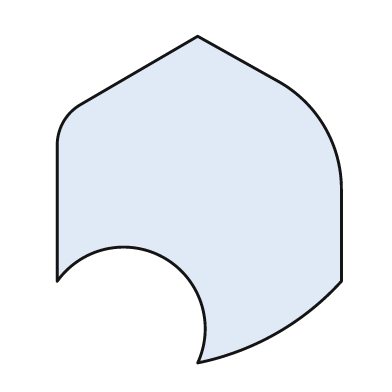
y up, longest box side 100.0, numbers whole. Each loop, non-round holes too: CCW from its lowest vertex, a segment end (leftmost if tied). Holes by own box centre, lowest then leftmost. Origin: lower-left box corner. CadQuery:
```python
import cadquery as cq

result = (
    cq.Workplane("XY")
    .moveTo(43.0, 0.0)
    .threePointArc((67.0, 9.0), (87.0, 25.0))
    .lineTo(87.0, 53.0)
    .threePointArc((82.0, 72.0), (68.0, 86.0))
    .lineTo(43.0, 100.0)
    .lineTo(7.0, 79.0)
    .threePointArc((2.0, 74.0), (0.0, 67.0))
    .lineTo(0.0, 25.0)
    .threePointArc((33.0, 32.0), (43.0, 0.0))
    .close()
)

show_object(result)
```